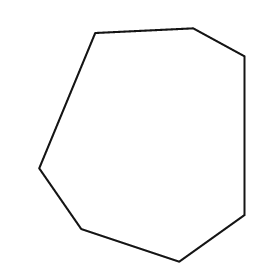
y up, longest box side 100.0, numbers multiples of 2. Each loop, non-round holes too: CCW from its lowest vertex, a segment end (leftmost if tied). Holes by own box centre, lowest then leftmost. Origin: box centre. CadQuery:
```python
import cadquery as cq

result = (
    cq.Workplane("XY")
    .moveTo(16.0, -50.0)
    .lineTo(44.0, -30.0)
    .lineTo(44.0, 38.0)
    .lineTo(22.0, 50.0)
    .lineTo(-20.0, 48.0)
    .lineTo(-44.0, -10.0)
    .lineTo(-26.0, -36.0)
    .close()
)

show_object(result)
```